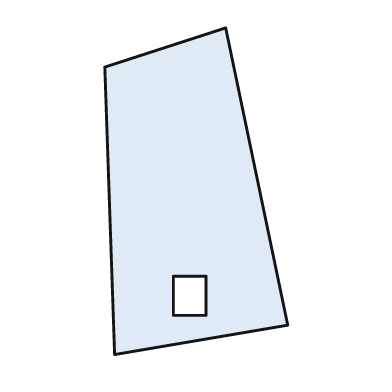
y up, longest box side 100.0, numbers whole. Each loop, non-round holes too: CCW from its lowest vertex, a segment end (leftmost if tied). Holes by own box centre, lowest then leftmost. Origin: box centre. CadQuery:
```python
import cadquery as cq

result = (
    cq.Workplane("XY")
    .moveTo(-25.0, -50.0)
    .lineTo(28.0, -41.0)
    .lineTo(9.0, 50.0)
    .lineTo(-28.0, 38.0)
    .close()
    .moveTo(-7.0, -38.0)
    .lineTo(3.0, -38.0)
    .lineTo(3.0, -26.0)
    .lineTo(-7.0, -26.0)
    .close()
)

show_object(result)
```